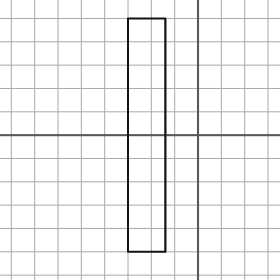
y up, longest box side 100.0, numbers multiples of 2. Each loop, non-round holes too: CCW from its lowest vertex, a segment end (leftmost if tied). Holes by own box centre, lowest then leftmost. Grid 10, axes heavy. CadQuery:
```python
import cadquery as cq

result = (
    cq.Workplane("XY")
    .moveTo(-30.0, -50.0)
    .lineTo(-14.0, -50.0)
    .lineTo(-14.0, 50.0)
    .lineTo(-30.0, 50.0)
    .close()
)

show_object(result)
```